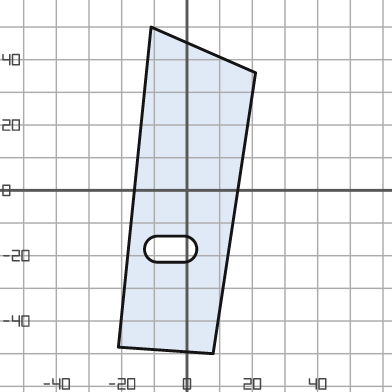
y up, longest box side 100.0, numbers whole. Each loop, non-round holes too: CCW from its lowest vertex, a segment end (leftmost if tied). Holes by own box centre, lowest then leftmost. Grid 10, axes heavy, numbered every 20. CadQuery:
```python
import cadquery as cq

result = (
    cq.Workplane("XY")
    .moveTo(8.0, -50.0)
    .lineTo(21.0, 36.0)
    .lineTo(-11.0, 50.0)
    .lineTo(-21.0, -48.0)
    .close()
    .moveTo(-9.0, -22.0)
    .lineTo(-1.0, -22.0)
    .threePointArc((3.0, -18.0), (-1.0, -14.0))
    .lineTo(-9.0, -14.0)
    .threePointArc((-13.0, -18.0), (-9.0, -22.0))
    .close()
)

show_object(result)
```